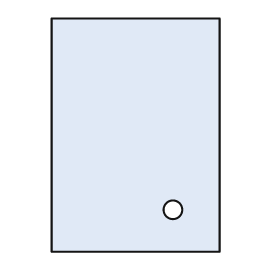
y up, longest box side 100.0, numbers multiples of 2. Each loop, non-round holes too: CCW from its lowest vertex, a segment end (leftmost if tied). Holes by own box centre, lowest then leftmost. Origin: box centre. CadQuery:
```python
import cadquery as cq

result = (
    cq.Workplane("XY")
    .moveTo(-36.0, -50.0)
    .lineTo(36.0, -50.0)
    .lineTo(36.0, 50.0)
    .lineTo(-36.0, 50.0)
    .close()
    .moveTo(16.0, -32.0)
    .circle(4.0)
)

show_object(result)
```